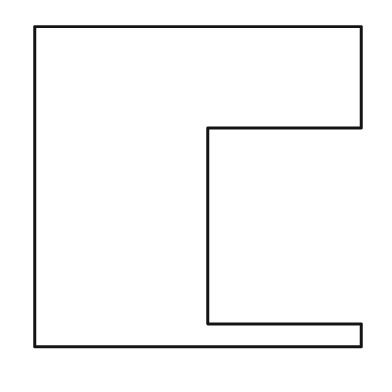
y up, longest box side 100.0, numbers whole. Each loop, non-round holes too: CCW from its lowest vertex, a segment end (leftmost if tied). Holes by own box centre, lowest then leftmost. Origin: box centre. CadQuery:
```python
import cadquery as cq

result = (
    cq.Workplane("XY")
    .moveTo(-50.0, -49.0)
    .lineTo(50.0, -49.0)
    .lineTo(50.0, -42.0)
    .lineTo(3.0, -42.0)
    .lineTo(3.0, 18.0)
    .lineTo(50.0, 18.0)
    .lineTo(50.0, 49.0)
    .lineTo(-50.0, 49.0)
    .close()
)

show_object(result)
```